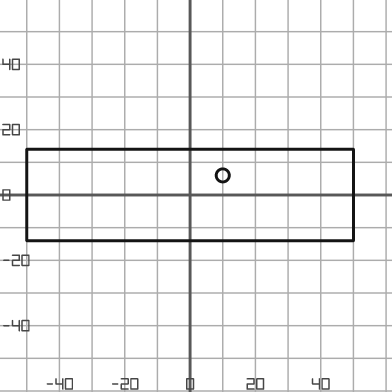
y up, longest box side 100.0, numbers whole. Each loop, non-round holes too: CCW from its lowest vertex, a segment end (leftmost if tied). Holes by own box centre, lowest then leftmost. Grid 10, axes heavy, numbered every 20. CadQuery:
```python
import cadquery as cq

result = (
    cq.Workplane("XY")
    .moveTo(-50.0, -14.0)
    .lineTo(50.0, -14.0)
    .lineTo(50.0, 14.0)
    .lineTo(-50.0, 14.0)
    .close()
    .moveTo(10.0, 6.0)
    .circle(2.0)
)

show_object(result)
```